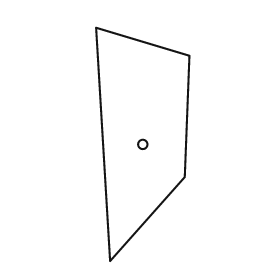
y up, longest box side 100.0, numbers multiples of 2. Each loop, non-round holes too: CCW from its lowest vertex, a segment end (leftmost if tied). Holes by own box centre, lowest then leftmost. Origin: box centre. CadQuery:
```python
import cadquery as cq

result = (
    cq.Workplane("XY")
    .moveTo(-14.0, -50.0)
    .lineTo(18.0, -14.0)
    .lineTo(20.0, 38.0)
    .lineTo(-20.0, 50.0)
    .close()
    .moveTo(0.0, 0.0)
    .circle(2.0)
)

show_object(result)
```